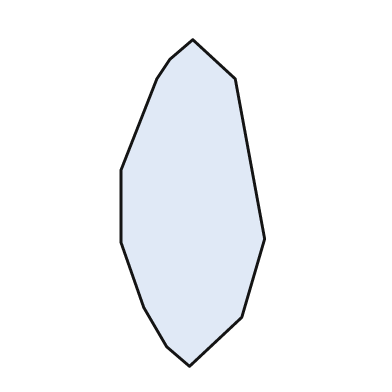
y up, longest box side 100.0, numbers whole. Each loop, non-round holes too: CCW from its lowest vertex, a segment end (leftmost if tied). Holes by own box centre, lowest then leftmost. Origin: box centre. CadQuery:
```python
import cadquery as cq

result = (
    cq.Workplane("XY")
    .moveTo(-1.0, -50.0)
    .lineTo(15.0, -35.0)
    .lineTo(22.0, -11.0)
    .lineTo(13.0, 38.0)
    .lineTo(0.0, 50.0)
    .lineTo(-7.0, 44.0)
    .lineTo(-11.0, 38.0)
    .lineTo(-22.0, 10.0)
    .lineTo(-22.0, -12.0)
    .lineTo(-15.0, -32.0)
    .lineTo(-8.0, -44.0)
    .close()
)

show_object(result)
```